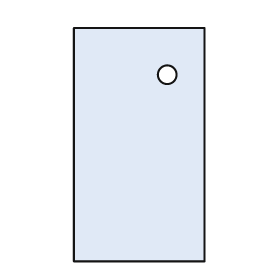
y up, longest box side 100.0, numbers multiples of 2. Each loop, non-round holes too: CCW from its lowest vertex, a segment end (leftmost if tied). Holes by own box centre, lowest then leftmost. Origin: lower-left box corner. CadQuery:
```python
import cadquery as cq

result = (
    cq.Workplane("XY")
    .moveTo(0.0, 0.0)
    .lineTo(56.0, 0.0)
    .lineTo(56.0, 100.0)
    .lineTo(0.0, 100.0)
    .close()
    .moveTo(40.0, 80.0)
    .circle(4.0)
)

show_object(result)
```